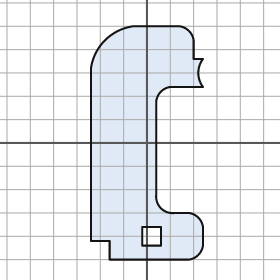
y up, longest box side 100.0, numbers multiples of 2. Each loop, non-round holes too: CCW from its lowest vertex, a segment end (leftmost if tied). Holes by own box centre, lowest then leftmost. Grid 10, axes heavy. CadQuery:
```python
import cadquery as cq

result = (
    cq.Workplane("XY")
    .moveTo(-16.0, -50.0)
    .lineTo(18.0, -50.0)
    .threePointArc((22.0, -48.0), (24.0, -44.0))
    .lineTo(24.0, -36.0)
    .threePointArc((22.0, -32.0), (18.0, -30.0))
    .lineTo(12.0, -30.0)
    .threePointArc((6.0, -28.0), (4.0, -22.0))
    .lineTo(4.0, 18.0)
    .threePointArc((6.0, 22.0), (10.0, 24.0))
    .lineTo(24.0, 24.0)
    .threePointArc((22.0, 30.0), (24.0, 36.0))
    .lineTo(20.0, 36.0)
    .lineTo(20.0, 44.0)
    .threePointArc((18.0, 48.0), (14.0, 50.0))
    .lineTo(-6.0, 50.0)
    .threePointArc((-18.0, 44.0), (-24.0, 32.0))
    .lineTo(-24.0, -42.0)
    .lineTo(-16.0, -42.0)
    .close()
    .moveTo(-2.0, -44.0)
    .lineTo(6.0, -44.0)
    .lineTo(6.0, -36.0)
    .lineTo(-2.0, -36.0)
    .close()
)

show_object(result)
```